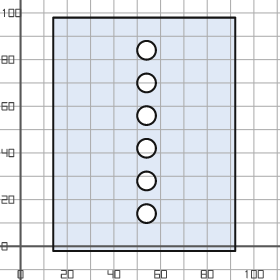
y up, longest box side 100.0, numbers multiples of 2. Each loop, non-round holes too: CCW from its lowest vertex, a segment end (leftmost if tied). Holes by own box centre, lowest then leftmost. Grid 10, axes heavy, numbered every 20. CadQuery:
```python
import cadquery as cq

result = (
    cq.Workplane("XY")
    .moveTo(14.0, -2.0)
    .lineTo(92.0, -2.0)
    .lineTo(92.0, 98.0)
    .lineTo(14.0, 98.0)
    .close()
    .moveTo(54.0, 14.0)
    .circle(4.0)
    .moveTo(54.0, 28.0)
    .circle(4.0)
    .moveTo(54.0, 42.0)
    .circle(4.0)
    .moveTo(54.0, 56.0)
    .circle(4.0)
    .moveTo(54.0, 70.0)
    .circle(4.0)
    .moveTo(54.0, 84.0)
    .circle(4.0)
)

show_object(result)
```